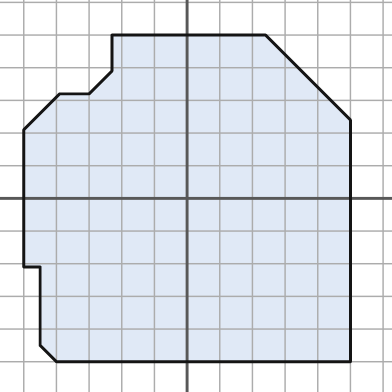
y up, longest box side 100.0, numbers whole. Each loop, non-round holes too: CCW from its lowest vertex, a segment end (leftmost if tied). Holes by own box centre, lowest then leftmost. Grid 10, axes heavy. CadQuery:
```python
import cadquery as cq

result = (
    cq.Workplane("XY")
    .moveTo(-40.0, -50.0)
    .lineTo(50.0, -50.0)
    .lineTo(50.0, 24.0)
    .lineTo(24.0, 50.0)
    .lineTo(-23.0, 50.0)
    .lineTo(-23.0, 39.0)
    .lineTo(-30.0, 32.0)
    .lineTo(-39.0, 32.0)
    .lineTo(-50.0, 21.0)
    .lineTo(-50.0, -21.0)
    .lineTo(-45.0, -21.0)
    .lineTo(-45.0, -45.0)
    .close()
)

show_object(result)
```